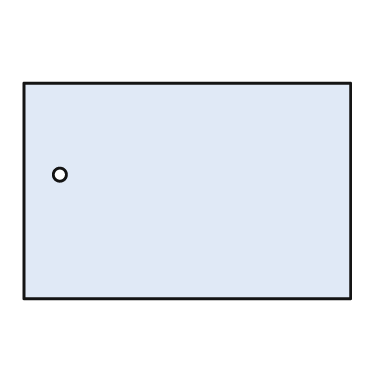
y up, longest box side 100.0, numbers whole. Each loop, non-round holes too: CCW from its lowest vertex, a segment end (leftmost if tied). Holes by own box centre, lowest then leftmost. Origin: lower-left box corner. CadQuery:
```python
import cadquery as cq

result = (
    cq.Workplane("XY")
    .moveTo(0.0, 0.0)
    .lineTo(100.0, 0.0)
    .lineTo(100.0, 66.0)
    .lineTo(0.0, 66.0)
    .close()
    .moveTo(11.0, 38.0)
    .circle(2.0)
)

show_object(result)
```